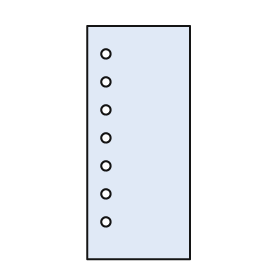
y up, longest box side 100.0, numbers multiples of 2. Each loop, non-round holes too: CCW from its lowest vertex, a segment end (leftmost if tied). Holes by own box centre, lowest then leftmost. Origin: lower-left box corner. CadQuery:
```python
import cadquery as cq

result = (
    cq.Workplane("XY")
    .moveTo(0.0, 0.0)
    .lineTo(44.0, 0.0)
    .lineTo(44.0, 100.0)
    .lineTo(0.0, 100.0)
    .close()
    .moveTo(8.0, 16.0)
    .circle(2.0)
    .moveTo(8.0, 28.0)
    .circle(2.0)
    .moveTo(8.0, 40.0)
    .circle(2.0)
    .moveTo(8.0, 52.0)
    .circle(2.0)
    .moveTo(8.0, 64.0)
    .circle(2.0)
    .moveTo(8.0, 76.0)
    .circle(2.0)
    .moveTo(8.0, 88.0)
    .circle(2.0)
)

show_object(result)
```